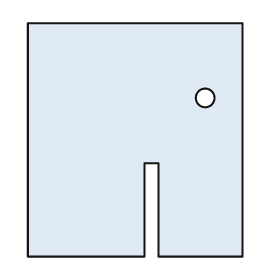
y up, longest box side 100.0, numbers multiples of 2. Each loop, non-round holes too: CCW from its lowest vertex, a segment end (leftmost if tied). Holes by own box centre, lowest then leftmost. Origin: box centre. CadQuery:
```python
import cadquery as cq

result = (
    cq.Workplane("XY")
    .moveTo(-46.0, -50.0)
    .lineTo(4.0, -50.0)
    .lineTo(4.0, -10.0)
    .lineTo(10.0, -10.0)
    .lineTo(10.0, -50.0)
    .lineTo(46.0, -50.0)
    .lineTo(46.0, 50.0)
    .lineTo(-46.0, 50.0)
    .close()
    .moveTo(30.0, 18.0)
    .circle(4.0)
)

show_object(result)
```